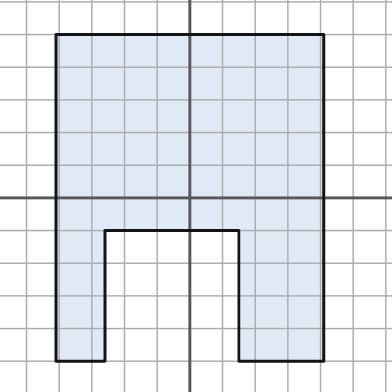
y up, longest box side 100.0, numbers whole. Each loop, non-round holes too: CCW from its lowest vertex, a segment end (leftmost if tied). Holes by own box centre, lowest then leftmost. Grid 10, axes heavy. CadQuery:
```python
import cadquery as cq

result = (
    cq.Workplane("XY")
    .moveTo(-41.0, -50.0)
    .lineTo(-26.0, -50.0)
    .lineTo(-26.0, -10.0)
    .lineTo(15.0, -10.0)
    .lineTo(15.0, -50.0)
    .lineTo(41.0, -50.0)
    .lineTo(41.0, 50.0)
    .lineTo(-41.0, 50.0)
    .close()
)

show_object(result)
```